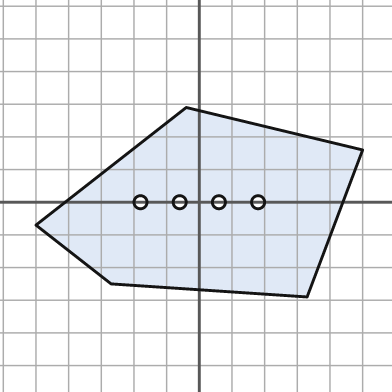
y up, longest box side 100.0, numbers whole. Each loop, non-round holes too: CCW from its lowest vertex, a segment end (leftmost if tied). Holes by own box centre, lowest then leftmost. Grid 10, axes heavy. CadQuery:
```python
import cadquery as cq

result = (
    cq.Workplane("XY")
    .moveTo(33.0, -29.0)
    .lineTo(50.0, 16.0)
    .lineTo(-4.0, 29.0)
    .lineTo(-50.0, -7.0)
    .lineTo(-27.0, -25.0)
    .close()
    .moveTo(-18.0, 0.0)
    .circle(2.0)
    .moveTo(-6.0, 0.0)
    .circle(2.0)
    .moveTo(6.0, 0.0)
    .circle(2.0)
    .moveTo(18.0, 0.0)
    .circle(2.0)
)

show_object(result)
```